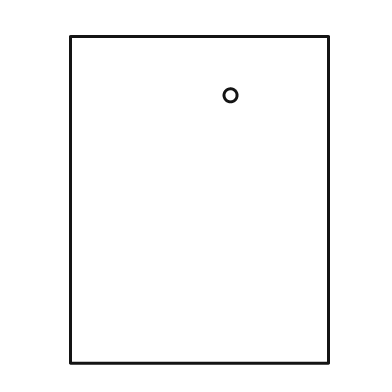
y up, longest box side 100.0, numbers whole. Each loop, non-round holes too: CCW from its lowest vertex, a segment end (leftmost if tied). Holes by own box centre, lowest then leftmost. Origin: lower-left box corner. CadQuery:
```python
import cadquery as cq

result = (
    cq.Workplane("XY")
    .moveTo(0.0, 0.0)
    .lineTo(79.0, 0.0)
    .lineTo(79.0, 100.0)
    .lineTo(0.0, 100.0)
    .close()
    .moveTo(49.0, 82.0)
    .circle(2.0)
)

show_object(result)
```